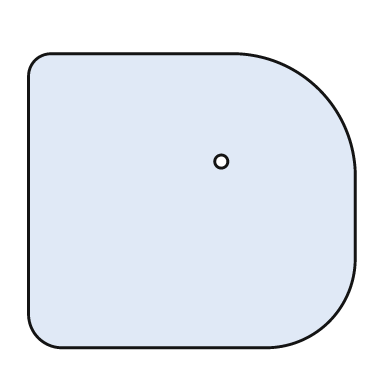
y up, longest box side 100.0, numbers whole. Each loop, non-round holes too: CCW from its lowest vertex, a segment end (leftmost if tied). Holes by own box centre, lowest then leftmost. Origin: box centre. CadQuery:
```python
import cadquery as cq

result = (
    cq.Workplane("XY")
    .moveTo(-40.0, -45.0)
    .lineTo(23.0, -45.0)
    .threePointArc((42.0, -37.0), (50.0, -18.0))
    .lineTo(50.0, 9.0)
    .threePointArc((39.0, 34.0), (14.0, 45.0))
    .lineTo(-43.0, 45.0)
    .threePointArc((-48.0, 43.0), (-50.0, 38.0))
    .lineTo(-50.0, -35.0)
    .threePointArc((-47.0, -42.0), (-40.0, -45.0))
    .close()
    .moveTo(9.0, 12.0)
    .circle(2.0)
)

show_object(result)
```